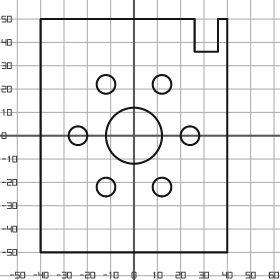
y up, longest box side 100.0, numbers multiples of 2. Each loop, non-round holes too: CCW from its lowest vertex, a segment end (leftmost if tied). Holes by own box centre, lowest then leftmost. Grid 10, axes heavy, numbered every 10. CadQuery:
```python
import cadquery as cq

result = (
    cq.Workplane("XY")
    .moveTo(-40.0, -50.0)
    .lineTo(40.0, -50.0)
    .lineTo(40.0, 50.0)
    .lineTo(36.0, 50.0)
    .lineTo(36.0, 36.0)
    .lineTo(26.0, 36.0)
    .lineTo(26.0, 50.0)
    .lineTo(-40.0, 50.0)
    .close()
    .moveTo(-12.0, -22.0)
    .circle(4.0)
    .moveTo(12.0, -22.0)
    .circle(4.0)
    .moveTo(-24.0, 0.0)
    .circle(4.0)
    .moveTo(0.0, 0.0)
    .circle(12.0)
    .moveTo(24.0, 0.0)
    .circle(4.0)
    .moveTo(-12.0, 22.0)
    .circle(4.0)
    .moveTo(12.0, 22.0)
    .circle(4.0)
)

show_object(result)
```